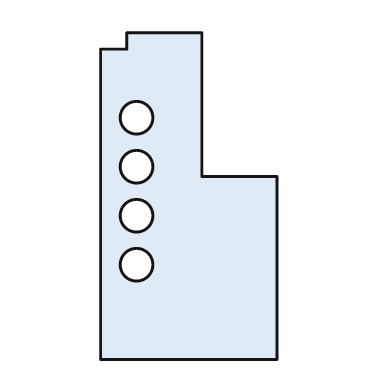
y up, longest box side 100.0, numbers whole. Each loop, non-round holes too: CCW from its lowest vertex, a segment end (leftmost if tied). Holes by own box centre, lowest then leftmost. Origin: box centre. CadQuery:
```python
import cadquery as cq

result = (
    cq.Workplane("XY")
    .moveTo(-27.0, -50.0)
    .lineTo(27.0, -50.0)
    .lineTo(27.0, 6.0)
    .lineTo(4.0, 6.0)
    .lineTo(4.0, 50.0)
    .lineTo(-19.0, 50.0)
    .lineTo(-19.0, 45.0)
    .lineTo(-27.0, 45.0)
    .close()
    .moveTo(-16.0, -21.0)
    .circle(5.0)
    .moveTo(-16.0, -6.0)
    .circle(5.0)
    .moveTo(-16.0, 9.0)
    .circle(5.0)
    .moveTo(-16.0, 24.0)
    .circle(5.0)
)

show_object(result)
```